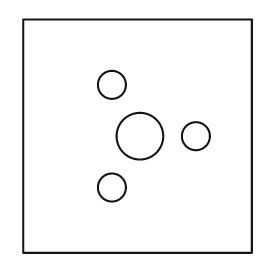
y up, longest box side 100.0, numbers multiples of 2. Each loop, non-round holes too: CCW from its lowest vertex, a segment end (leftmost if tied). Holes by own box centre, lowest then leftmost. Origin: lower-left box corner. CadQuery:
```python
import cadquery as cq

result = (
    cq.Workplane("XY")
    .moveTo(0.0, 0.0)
    .lineTo(98.0, 0.0)
    .lineTo(98.0, 100.0)
    .lineTo(0.0, 100.0)
    .close()
    .moveTo(38.0, 28.0)
    .circle(6.0)
    .moveTo(50.0, 50.0)
    .circle(10.0)
    .moveTo(74.0, 50.0)
    .circle(6.0)
    .moveTo(38.0, 72.0)
    .circle(6.0)
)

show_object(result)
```